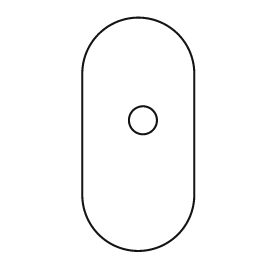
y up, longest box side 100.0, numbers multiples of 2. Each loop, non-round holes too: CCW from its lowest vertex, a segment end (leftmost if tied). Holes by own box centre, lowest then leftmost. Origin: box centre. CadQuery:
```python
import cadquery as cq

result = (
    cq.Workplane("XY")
    .moveTo(-24.0, -26.0)
    .threePointArc((0.0, -50.0), (24.0, -26.0))
    .lineTo(24.0, 26.0)
    .threePointArc((0.0, 50.0), (-24.0, 26.0))
    .close()
    .moveTo(2.0, 6.0)
    .circle(6.0)
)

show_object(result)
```